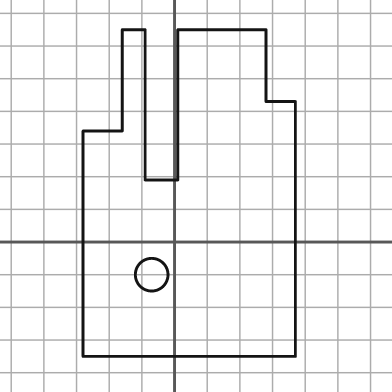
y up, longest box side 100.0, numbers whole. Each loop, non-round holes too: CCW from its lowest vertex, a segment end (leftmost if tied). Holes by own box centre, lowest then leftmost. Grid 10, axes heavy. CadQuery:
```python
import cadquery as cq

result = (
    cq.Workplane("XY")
    .moveTo(-28.0, -35.0)
    .lineTo(37.0, -35.0)
    .lineTo(37.0, 43.0)
    .lineTo(28.0, 43.0)
    .lineTo(28.0, 65.0)
    .lineTo(1.0, 65.0)
    .lineTo(1.0, 19.0)
    .lineTo(-9.0, 19.0)
    .lineTo(-9.0, 65.0)
    .lineTo(-16.0, 65.0)
    .lineTo(-16.0, 34.0)
    .lineTo(-28.0, 34.0)
    .close()
    .moveTo(-7.0, -10.0)
    .circle(5.0)
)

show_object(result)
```